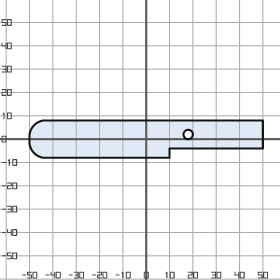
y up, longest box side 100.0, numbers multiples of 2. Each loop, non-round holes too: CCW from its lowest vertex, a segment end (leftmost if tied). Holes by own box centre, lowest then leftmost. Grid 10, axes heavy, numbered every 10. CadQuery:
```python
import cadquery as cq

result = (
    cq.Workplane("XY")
    .moveTo(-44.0, -8.0)
    .lineTo(10.0, -8.0)
    .lineTo(10.0, -4.0)
    .lineTo(50.0, -4.0)
    .lineTo(50.0, 8.0)
    .lineTo(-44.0, 8.0)
    .threePointArc((-48.0, 6.0), (-50.0, 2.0))
    .lineTo(-50.0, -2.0)
    .threePointArc((-48.0, -6.0), (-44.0, -8.0))
    .close()
    .moveTo(18.0, 2.0)
    .circle(2.0)
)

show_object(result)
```